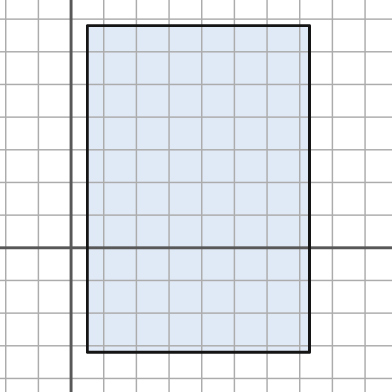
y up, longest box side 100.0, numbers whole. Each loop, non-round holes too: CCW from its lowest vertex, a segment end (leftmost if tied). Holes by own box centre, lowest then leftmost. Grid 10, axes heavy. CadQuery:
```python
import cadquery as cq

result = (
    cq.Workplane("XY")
    .moveTo(5.0, -32.0)
    .lineTo(73.0, -32.0)
    .lineTo(73.0, 68.0)
    .lineTo(5.0, 68.0)
    .close()
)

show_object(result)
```